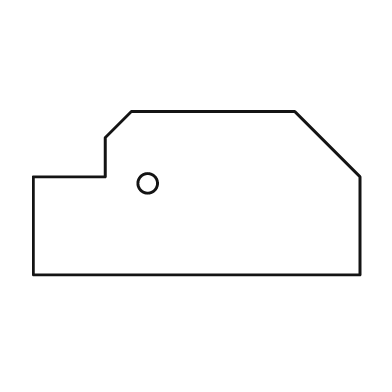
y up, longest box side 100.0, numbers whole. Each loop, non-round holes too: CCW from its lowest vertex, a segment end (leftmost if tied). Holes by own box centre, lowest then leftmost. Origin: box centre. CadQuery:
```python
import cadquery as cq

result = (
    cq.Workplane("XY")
    .moveTo(-50.0, -25.0)
    .lineTo(50.0, -25.0)
    .lineTo(50.0, 5.0)
    .lineTo(30.0, 25.0)
    .lineTo(-20.0, 25.0)
    .lineTo(-28.0, 17.0)
    .lineTo(-28.0, 5.0)
    .lineTo(-50.0, 5.0)
    .close()
    .moveTo(-15.0, 3.0)
    .circle(3.0)
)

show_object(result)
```